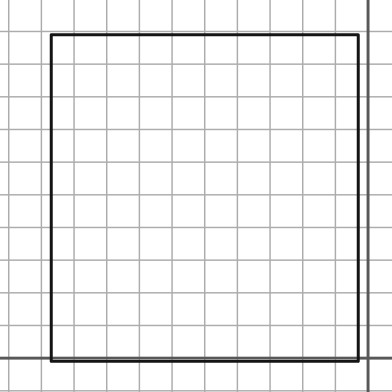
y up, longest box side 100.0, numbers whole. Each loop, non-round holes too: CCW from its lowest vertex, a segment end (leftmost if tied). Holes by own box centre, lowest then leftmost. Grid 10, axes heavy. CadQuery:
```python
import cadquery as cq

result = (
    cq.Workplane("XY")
    .moveTo(-97.0, -1.0)
    .lineTo(-3.0, -1.0)
    .lineTo(-3.0, 99.0)
    .lineTo(-97.0, 99.0)
    .close()
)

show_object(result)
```